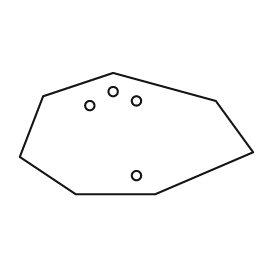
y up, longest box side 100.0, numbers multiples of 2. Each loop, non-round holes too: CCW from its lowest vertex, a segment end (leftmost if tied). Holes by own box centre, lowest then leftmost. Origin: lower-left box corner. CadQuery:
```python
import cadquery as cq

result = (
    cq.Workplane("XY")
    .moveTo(24.0, 0.0)
    .lineTo(58.0, 0.0)
    .lineTo(100.0, 18.0)
    .lineTo(84.0, 40.0)
    .lineTo(40.0, 52.0)
    .lineTo(10.0, 42.0)
    .lineTo(0.0, 16.0)
    .close()
    .moveTo(50.0, 8.0)
    .circle(2.0)
    .moveTo(30.0, 38.0)
    .circle(2.0)
    .moveTo(50.0, 40.0)
    .circle(2.0)
    .moveTo(40.0, 44.0)
    .circle(2.0)
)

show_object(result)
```